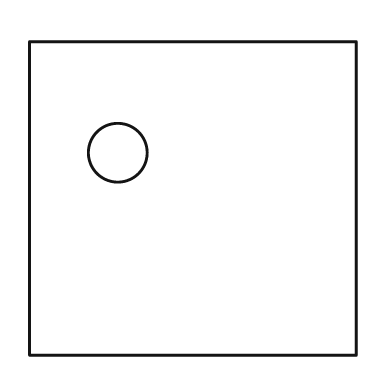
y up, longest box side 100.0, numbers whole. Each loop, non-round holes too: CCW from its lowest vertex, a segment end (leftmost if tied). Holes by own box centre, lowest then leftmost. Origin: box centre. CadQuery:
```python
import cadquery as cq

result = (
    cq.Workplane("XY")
    .moveTo(-50.0, -48.0)
    .lineTo(50.0, -48.0)
    .lineTo(50.0, 48.0)
    .lineTo(-50.0, 48.0)
    .close()
    .moveTo(-23.0, 14.0)
    .circle(9.0)
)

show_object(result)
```